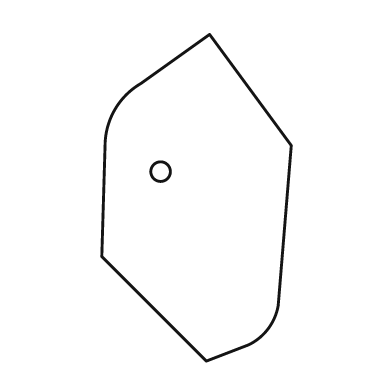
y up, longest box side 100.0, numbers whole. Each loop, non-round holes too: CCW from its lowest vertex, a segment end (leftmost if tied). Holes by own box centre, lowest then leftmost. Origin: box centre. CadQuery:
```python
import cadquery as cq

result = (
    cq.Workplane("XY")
    .moveTo(3.0, -50.0)
    .lineTo(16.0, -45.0)
    .threePointArc((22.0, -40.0), (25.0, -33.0))
    .lineTo(29.0, 16.0)
    .lineTo(4.0, 50.0)
    .lineTo(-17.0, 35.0)
    .threePointArc((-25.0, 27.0), (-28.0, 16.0))
    .lineTo(-29.0, -18.0)
    .close()
    .moveTo(-11.0, 8.0)
    .circle(3.0)
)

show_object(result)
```